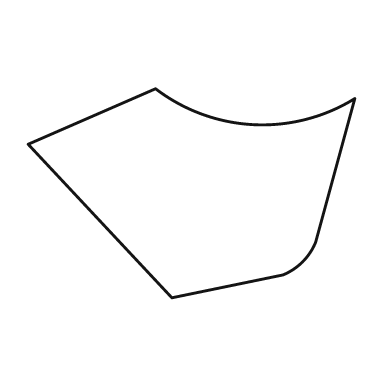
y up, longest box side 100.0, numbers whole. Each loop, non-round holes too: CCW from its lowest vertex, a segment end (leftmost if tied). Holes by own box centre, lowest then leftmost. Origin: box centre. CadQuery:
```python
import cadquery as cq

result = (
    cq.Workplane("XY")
    .moveTo(-6.0, -32.0)
    .lineTo(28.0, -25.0)
    .threePointArc((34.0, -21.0), (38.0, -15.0))
    .lineTo(50.0, 29.0)
    .threePointArc((19.0, 21.0), (-11.0, 32.0))
    .lineTo(-50.0, 15.0)
    .close()
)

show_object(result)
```